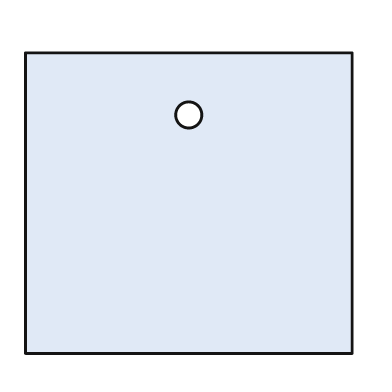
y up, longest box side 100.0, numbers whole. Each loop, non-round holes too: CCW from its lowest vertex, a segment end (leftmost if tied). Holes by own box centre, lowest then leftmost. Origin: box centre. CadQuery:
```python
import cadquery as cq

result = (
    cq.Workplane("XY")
    .moveTo(-50.0, -46.0)
    .lineTo(50.0, -46.0)
    .lineTo(50.0, 46.0)
    .lineTo(-50.0, 46.0)
    .close()
    .moveTo(0.0, 27.0)
    .circle(4.0)
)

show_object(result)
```